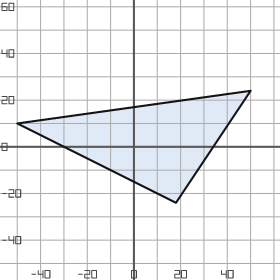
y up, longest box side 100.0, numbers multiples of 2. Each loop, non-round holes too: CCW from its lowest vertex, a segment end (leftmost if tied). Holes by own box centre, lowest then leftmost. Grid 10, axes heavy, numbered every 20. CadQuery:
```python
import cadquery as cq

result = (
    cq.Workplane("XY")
    .moveTo(18.0, -24.0)
    .lineTo(50.0, 24.0)
    .lineTo(-50.0, 10.0)
    .close()
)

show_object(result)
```